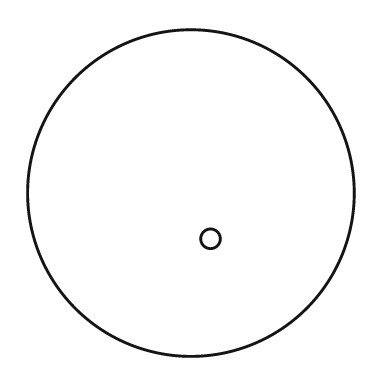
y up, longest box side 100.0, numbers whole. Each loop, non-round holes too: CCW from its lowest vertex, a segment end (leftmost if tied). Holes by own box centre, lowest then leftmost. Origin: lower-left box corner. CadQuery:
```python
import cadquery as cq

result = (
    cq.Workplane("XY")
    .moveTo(50.0, 50.0)
    .circle(50.0)
    .moveTo(56.0, 36.0)
    .circle(3.0)
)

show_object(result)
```